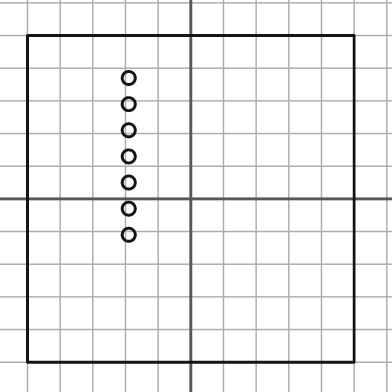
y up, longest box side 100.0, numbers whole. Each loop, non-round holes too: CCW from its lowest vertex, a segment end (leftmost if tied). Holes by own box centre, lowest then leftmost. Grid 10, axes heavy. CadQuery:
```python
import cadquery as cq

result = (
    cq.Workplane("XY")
    .moveTo(-50.0, -50.0)
    .lineTo(50.0, -50.0)
    .lineTo(50.0, 50.0)
    .lineTo(-50.0, 50.0)
    .close()
    .moveTo(-19.0, -11.0)
    .circle(2.0)
    .moveTo(-19.0, -3.0)
    .circle(2.0)
    .moveTo(-19.0, 5.0)
    .circle(2.0)
    .moveTo(-19.0, 13.0)
    .circle(2.0)
    .moveTo(-19.0, 21.0)
    .circle(2.0)
    .moveTo(-19.0, 29.0)
    .circle(2.0)
    .moveTo(-19.0, 37.0)
    .circle(2.0)
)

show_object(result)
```